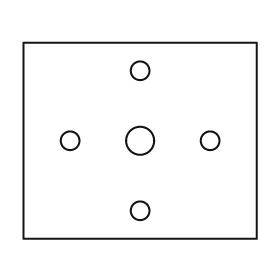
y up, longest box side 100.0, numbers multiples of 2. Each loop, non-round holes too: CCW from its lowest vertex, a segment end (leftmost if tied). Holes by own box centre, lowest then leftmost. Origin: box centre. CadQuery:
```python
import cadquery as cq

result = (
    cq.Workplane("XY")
    .moveTo(-50.0, -42.0)
    .lineTo(50.0, -42.0)
    .lineTo(50.0, 42.0)
    .lineTo(-50.0, 42.0)
    .close()
    .moveTo(0.0, -30.0)
    .circle(4.0)
    .moveTo(-30.0, 0.0)
    .circle(4.0)
    .moveTo(0.0, 0.0)
    .circle(6.0)
    .moveTo(30.0, 0.0)
    .circle(4.0)
    .moveTo(0.0, 30.0)
    .circle(4.0)
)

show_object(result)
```